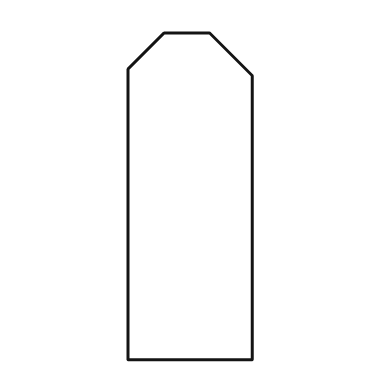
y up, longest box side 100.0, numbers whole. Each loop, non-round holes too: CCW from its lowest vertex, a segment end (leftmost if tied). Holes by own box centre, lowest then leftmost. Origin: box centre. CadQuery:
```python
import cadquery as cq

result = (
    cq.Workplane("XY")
    .moveTo(-19.0, -50.0)
    .lineTo(19.0, -50.0)
    .lineTo(19.0, 37.0)
    .lineTo(6.0, 50.0)
    .lineTo(-8.0, 50.0)
    .lineTo(-19.0, 39.0)
    .close()
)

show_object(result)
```